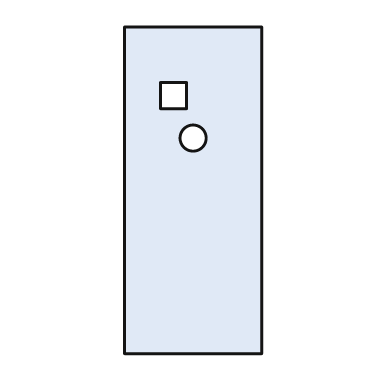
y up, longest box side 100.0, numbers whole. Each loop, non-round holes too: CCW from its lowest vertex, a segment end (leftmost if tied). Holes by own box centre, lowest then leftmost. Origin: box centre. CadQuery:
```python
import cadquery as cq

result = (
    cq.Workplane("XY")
    .moveTo(-21.0, -50.0)
    .lineTo(21.0, -50.0)
    .lineTo(21.0, 50.0)
    .lineTo(-21.0, 50.0)
    .close()
    .moveTo(0.0, 16.0)
    .circle(4.0)
    .moveTo(-10.0, 25.0)
    .lineTo(-2.0, 25.0)
    .lineTo(-2.0, 33.0)
    .lineTo(-10.0, 33.0)
    .close()
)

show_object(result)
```